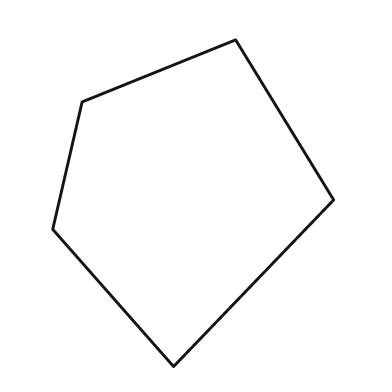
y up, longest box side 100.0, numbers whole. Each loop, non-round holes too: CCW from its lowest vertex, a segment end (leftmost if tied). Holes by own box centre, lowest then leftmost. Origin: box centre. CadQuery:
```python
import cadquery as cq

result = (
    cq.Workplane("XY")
    .moveTo(-6.0, -50.0)
    .lineTo(43.0, 1.0)
    .lineTo(13.0, 50.0)
    .lineTo(-34.0, 31.0)
    .lineTo(-43.0, -8.0)
    .close()
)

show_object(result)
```